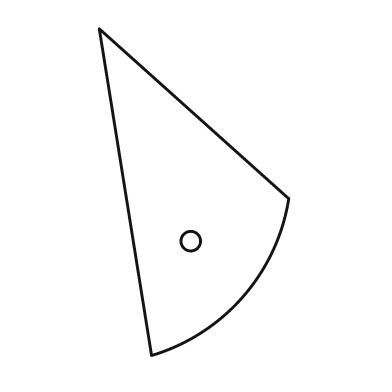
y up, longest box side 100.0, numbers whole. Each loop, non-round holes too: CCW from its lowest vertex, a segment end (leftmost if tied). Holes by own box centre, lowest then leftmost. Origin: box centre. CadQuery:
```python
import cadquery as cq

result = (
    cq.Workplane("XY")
    .moveTo(-13.0, -50.0)
    .threePointArc((15.0, -32.0), (29.0, -2.0))
    .lineTo(-29.0, 50.0)
    .close()
    .moveTo(-1.0, -15.0)
    .circle(3.0)
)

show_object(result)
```